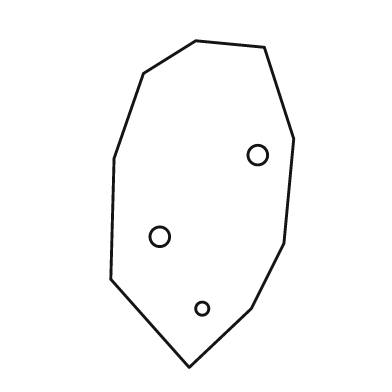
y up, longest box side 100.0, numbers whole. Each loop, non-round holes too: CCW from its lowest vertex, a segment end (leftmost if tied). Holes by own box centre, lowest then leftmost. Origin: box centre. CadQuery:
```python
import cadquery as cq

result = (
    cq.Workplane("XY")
    .moveTo(-4.0, -50.0)
    .lineTo(15.0, -32.0)
    .lineTo(25.0, -12.0)
    .lineTo(28.0, 20.0)
    .lineTo(19.0, 48.0)
    .lineTo(-2.0, 50.0)
    .lineTo(-18.0, 40.0)
    .lineTo(-27.0, 14.0)
    .lineTo(-28.0, -23.0)
    .close()
    .moveTo(0.0, -32.0)
    .circle(2.0)
    .moveTo(-13.0, -10.0)
    .circle(3.0)
    .moveTo(17.0, 15.0)
    .circle(3.0)
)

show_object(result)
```